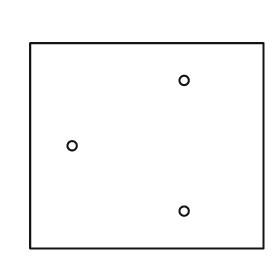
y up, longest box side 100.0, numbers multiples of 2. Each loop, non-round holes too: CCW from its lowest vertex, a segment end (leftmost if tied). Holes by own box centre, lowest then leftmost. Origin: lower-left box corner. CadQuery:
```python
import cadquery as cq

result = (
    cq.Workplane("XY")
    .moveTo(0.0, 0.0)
    .lineTo(100.0, 0.0)
    .lineTo(100.0, 88.0)
    .lineTo(0.0, 88.0)
    .close()
    .moveTo(66.0, 16.0)
    .circle(2.0)
    .moveTo(18.0, 44.0)
    .circle(2.0)
    .moveTo(66.0, 72.0)
    .circle(2.0)
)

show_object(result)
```